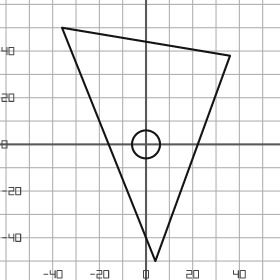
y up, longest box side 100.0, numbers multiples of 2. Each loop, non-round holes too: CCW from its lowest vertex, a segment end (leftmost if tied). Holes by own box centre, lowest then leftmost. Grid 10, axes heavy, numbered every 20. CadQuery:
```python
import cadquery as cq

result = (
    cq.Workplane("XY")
    .moveTo(4.0, -50.0)
    .lineTo(36.0, 38.0)
    .lineTo(-36.0, 50.0)
    .close()
    .moveTo(0.0, 0.0)
    .circle(6.0)
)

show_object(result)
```